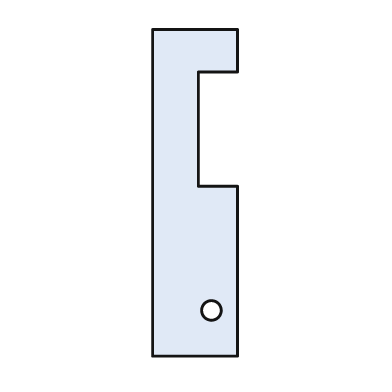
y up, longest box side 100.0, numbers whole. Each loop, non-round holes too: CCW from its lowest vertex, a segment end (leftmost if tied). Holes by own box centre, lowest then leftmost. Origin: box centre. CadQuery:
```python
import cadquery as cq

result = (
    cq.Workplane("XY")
    .moveTo(-13.0, -50.0)
    .lineTo(13.0, -50.0)
    .lineTo(13.0, 2.0)
    .lineTo(1.0, 2.0)
    .lineTo(1.0, 37.0)
    .lineTo(13.0, 37.0)
    .lineTo(13.0, 50.0)
    .lineTo(-13.0, 50.0)
    .close()
    .moveTo(5.0, -36.0)
    .circle(3.0)
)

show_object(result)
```